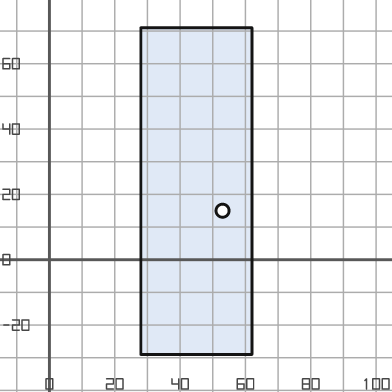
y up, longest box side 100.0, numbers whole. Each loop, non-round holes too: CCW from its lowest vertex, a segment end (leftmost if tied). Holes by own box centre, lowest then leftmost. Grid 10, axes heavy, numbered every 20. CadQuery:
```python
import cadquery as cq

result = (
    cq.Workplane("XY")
    .moveTo(28.0, -29.0)
    .lineTo(62.0, -29.0)
    .lineTo(62.0, 71.0)
    .lineTo(28.0, 71.0)
    .close()
    .moveTo(53.0, 15.0)
    .circle(2.0)
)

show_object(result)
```